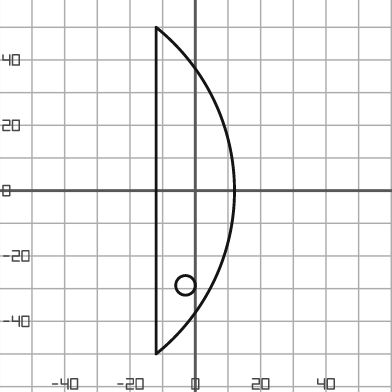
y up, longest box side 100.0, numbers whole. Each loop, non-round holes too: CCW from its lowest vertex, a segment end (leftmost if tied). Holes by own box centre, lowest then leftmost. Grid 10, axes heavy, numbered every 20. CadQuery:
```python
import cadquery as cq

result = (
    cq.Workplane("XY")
    .moveTo(-12.0, -50.0)
    .threePointArc((12.0, 0.0), (-12.0, 50.0))
    .close()
    .moveTo(-3.0, -29.0)
    .circle(3.0)
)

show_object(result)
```